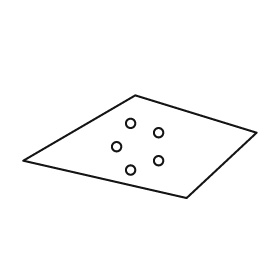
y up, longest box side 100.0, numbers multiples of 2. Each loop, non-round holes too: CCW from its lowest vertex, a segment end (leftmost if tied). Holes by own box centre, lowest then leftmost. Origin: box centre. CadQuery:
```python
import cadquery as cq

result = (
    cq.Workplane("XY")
    .moveTo(20.0, -22.0)
    .lineTo(50.0, 6.0)
    .lineTo(-2.0, 22.0)
    .lineTo(-50.0, -6.0)
    .close()
    .moveTo(-4.0, -10.0)
    .circle(2.0)
    .moveTo(8.0, -6.0)
    .circle(2.0)
    .moveTo(-10.0, 0.0)
    .circle(2.0)
    .moveTo(8.0, 6.0)
    .circle(2.0)
    .moveTo(-4.0, 10.0)
    .circle(2.0)
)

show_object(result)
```